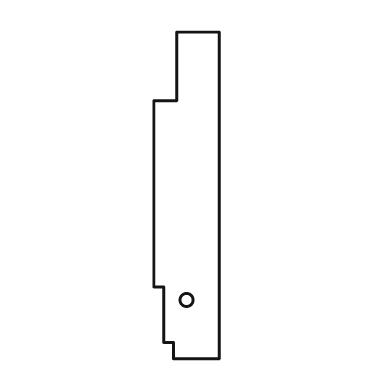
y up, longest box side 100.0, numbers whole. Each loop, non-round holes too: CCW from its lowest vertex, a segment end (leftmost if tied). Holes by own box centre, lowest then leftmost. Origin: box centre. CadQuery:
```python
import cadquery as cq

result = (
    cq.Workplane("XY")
    .moveTo(-4.0, -50.0)
    .lineTo(10.0, -50.0)
    .lineTo(10.0, 50.0)
    .lineTo(-3.0, 50.0)
    .lineTo(-3.0, 29.0)
    .lineTo(-10.0, 29.0)
    .lineTo(-10.0, -28.0)
    .lineTo(-7.0, -28.0)
    .lineTo(-7.0, -45.0)
    .lineTo(-4.0, -45.0)
    .close()
    .moveTo(0.0, -32.0)
    .circle(2.0)
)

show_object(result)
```